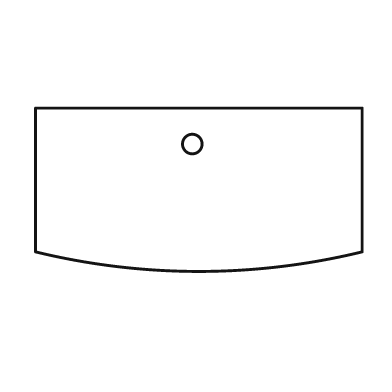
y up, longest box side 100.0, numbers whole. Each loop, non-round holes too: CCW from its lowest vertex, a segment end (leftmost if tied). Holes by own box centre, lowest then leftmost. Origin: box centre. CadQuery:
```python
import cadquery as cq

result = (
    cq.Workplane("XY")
    .moveTo(-50.0, -19.0)
    .threePointArc((0.0, -25.0), (50.0, -19.0))
    .lineTo(50.0, 25.0)
    .lineTo(-50.0, 25.0)
    .close()
    .moveTo(-2.0, 14.0)
    .circle(3.0)
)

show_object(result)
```